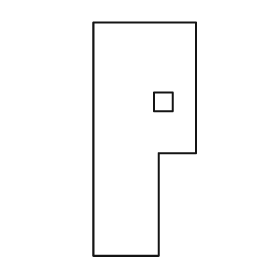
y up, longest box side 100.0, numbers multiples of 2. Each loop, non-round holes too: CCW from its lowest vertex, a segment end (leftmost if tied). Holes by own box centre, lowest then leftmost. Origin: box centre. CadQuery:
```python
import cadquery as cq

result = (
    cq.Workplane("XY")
    .moveTo(-22.0, -50.0)
    .lineTo(6.0, -50.0)
    .lineTo(6.0, -6.0)
    .lineTo(22.0, -6.0)
    .lineTo(22.0, 50.0)
    .lineTo(-22.0, 50.0)
    .close()
    .moveTo(4.0, 12.0)
    .lineTo(12.0, 12.0)
    .lineTo(12.0, 20.0)
    .lineTo(4.0, 20.0)
    .close()
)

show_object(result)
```